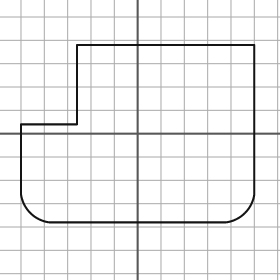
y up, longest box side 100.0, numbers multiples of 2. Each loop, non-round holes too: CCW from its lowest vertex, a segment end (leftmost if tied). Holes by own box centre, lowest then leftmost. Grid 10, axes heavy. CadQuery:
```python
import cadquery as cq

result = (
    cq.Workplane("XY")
    .moveTo(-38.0, -38.0)
    .lineTo(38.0, -38.0)
    .threePointArc((46.0, -34.0), (50.0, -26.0))
    .lineTo(50.0, 38.0)
    .lineTo(-26.0, 38.0)
    .lineTo(-26.0, 4.0)
    .lineTo(-50.0, 4.0)
    .lineTo(-50.0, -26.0)
    .threePointArc((-46.0, -34.0), (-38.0, -38.0))
    .close()
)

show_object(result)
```